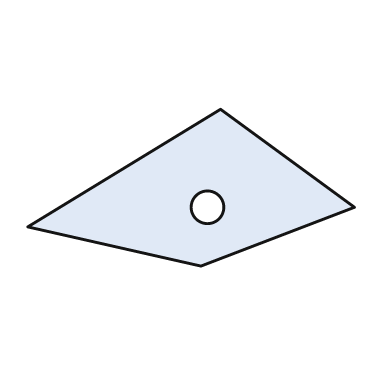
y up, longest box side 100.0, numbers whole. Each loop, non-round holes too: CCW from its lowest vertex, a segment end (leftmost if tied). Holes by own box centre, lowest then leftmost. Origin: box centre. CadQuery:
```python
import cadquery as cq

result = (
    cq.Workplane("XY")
    .moveTo(3.0, -24.0)
    .lineTo(50.0, -6.0)
    .lineTo(9.0, 24.0)
    .lineTo(-50.0, -12.0)
    .close()
    .moveTo(5.0, -6.0)
    .circle(5.0)
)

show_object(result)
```